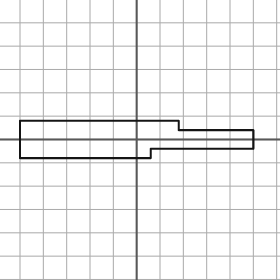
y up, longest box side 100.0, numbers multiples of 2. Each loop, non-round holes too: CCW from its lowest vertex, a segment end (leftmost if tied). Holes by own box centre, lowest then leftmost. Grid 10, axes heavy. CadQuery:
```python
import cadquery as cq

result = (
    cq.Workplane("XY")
    .moveTo(-50.0, -8.0)
    .lineTo(6.0, -8.0)
    .lineTo(6.0, -4.0)
    .lineTo(50.0, -4.0)
    .lineTo(50.0, 4.0)
    .lineTo(18.0, 4.0)
    .lineTo(18.0, 8.0)
    .lineTo(-50.0, 8.0)
    .close()
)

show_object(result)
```